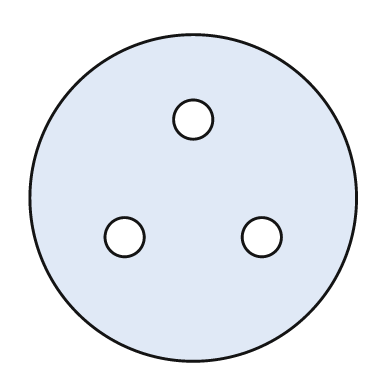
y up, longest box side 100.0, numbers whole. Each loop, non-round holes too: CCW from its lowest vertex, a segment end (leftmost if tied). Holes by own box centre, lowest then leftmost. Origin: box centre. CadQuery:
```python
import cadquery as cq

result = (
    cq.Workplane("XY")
    .moveTo(0.0, 0.0)
    .circle(50.0)
    .moveTo(-21.0, -12.0)
    .circle(6.0)
    .moveTo(21.0, -12.0)
    .circle(6.0)
    .moveTo(0.0, 24.0)
    .circle(6.0)
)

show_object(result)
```